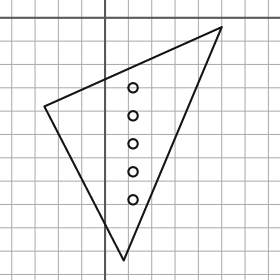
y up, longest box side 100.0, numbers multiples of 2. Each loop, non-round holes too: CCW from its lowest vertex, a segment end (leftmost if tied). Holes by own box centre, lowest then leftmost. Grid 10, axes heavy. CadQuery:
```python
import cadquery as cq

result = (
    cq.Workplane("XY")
    .moveTo(8.0, -104.0)
    .lineTo(50.0, -4.0)
    .lineTo(-26.0, -38.0)
    .close()
    .moveTo(12.0, -78.0)
    .circle(2.0)
    .moveTo(12.0, -66.0)
    .circle(2.0)
    .moveTo(12.0, -54.0)
    .circle(2.0)
    .moveTo(12.0, -42.0)
    .circle(2.0)
    .moveTo(12.0, -30.0)
    .circle(2.0)
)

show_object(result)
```